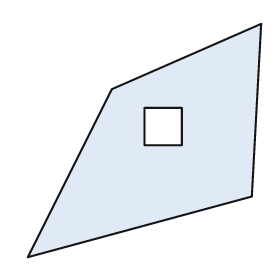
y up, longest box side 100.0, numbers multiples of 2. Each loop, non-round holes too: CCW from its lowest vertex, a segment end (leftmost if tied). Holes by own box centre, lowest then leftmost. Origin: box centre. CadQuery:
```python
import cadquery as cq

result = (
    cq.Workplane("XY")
    .moveTo(-50.0, -50.0)
    .lineTo(46.0, -24.0)
    .lineTo(50.0, 50.0)
    .lineTo(-14.0, 22.0)
    .close()
    .moveTo(0.0, -2.0)
    .lineTo(16.0, -2.0)
    .lineTo(16.0, 14.0)
    .lineTo(0.0, 14.0)
    .close()
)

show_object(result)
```